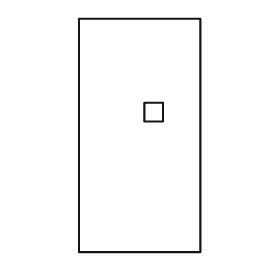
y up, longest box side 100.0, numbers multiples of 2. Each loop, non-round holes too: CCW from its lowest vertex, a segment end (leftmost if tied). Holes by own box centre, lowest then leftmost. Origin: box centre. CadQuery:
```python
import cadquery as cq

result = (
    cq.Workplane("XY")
    .moveTo(-26.0, -50.0)
    .lineTo(26.0, -50.0)
    .lineTo(26.0, 50.0)
    .lineTo(-26.0, 50.0)
    .close()
    .moveTo(2.0, 6.0)
    .lineTo(10.0, 6.0)
    .lineTo(10.0, 14.0)
    .lineTo(2.0, 14.0)
    .close()
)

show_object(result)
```